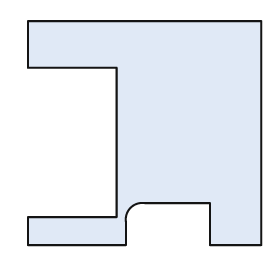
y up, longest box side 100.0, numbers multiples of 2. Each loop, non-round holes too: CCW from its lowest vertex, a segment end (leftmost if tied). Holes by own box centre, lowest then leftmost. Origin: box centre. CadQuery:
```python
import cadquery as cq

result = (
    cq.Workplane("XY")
    .moveTo(-50.0, -48.0)
    .lineTo(-8.0, -48.0)
    .lineTo(-8.0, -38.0)
    .threePointArc((-6.0, -32.0), (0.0, -30.0))
    .lineTo(28.0, -30.0)
    .lineTo(28.0, -48.0)
    .lineTo(50.0, -48.0)
    .lineTo(50.0, 48.0)
    .lineTo(-50.0, 48.0)
    .lineTo(-50.0, 28.0)
    .lineTo(-12.0, 28.0)
    .lineTo(-12.0, -36.0)
    .lineTo(-50.0, -36.0)
    .close()
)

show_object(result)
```